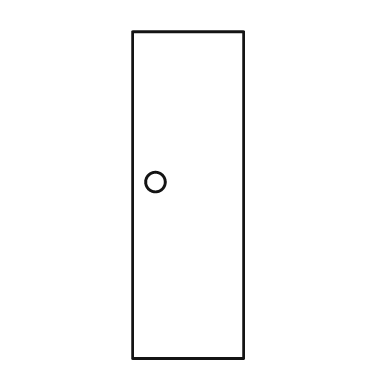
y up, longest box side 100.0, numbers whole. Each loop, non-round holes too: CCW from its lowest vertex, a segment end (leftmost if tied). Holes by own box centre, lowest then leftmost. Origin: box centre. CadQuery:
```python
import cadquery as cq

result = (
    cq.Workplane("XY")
    .moveTo(-17.0, -50.0)
    .lineTo(17.0, -50.0)
    .lineTo(17.0, 50.0)
    .lineTo(-17.0, 50.0)
    .close()
    .moveTo(-10.0, 4.0)
    .circle(3.0)
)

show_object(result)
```